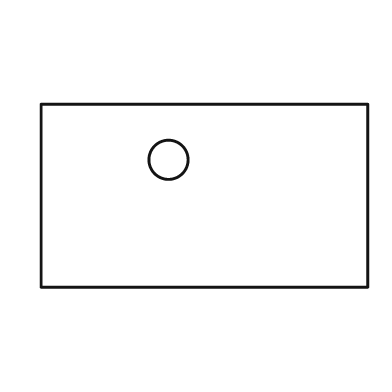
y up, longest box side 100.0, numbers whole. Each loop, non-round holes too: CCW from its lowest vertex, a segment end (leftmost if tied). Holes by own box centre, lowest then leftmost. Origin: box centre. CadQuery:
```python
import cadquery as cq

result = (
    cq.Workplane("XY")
    .moveTo(-50.0, -28.0)
    .lineTo(50.0, -28.0)
    .lineTo(50.0, 28.0)
    .lineTo(-50.0, 28.0)
    .close()
    .moveTo(-11.0, 11.0)
    .circle(6.0)
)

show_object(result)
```